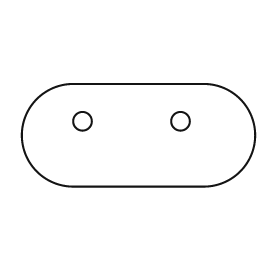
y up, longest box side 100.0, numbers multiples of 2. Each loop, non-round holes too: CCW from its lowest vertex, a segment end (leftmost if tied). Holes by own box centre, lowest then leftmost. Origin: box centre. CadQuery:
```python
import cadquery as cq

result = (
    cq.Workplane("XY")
    .moveTo(-28.0, -22.0)
    .lineTo(28.0, -22.0)
    .threePointArc((50.0, 0.0), (28.0, 22.0))
    .lineTo(-28.0, 22.0)
    .threePointArc((-50.0, 0.0), (-28.0, -22.0))
    .close()
    .moveTo(-24.0, 6.0)
    .circle(4.0)
    .moveTo(18.0, 6.0)
    .circle(4.0)
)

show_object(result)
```